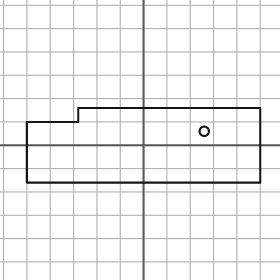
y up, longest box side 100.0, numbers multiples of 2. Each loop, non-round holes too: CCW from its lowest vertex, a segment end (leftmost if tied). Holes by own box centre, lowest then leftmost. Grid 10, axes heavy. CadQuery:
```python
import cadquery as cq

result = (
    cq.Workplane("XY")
    .moveTo(-50.0, -16.0)
    .lineTo(50.0, -16.0)
    .lineTo(50.0, 16.0)
    .lineTo(-28.0, 16.0)
    .lineTo(-28.0, 10.0)
    .lineTo(-50.0, 10.0)
    .close()
    .moveTo(26.0, 6.0)
    .circle(2.0)
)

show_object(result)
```